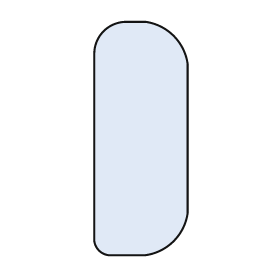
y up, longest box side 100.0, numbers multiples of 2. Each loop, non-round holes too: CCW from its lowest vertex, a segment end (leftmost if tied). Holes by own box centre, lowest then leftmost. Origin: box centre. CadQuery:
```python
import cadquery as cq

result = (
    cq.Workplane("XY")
    .moveTo(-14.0, -50.0)
    .lineTo(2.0, -50.0)
    .threePointArc((14.0, -44.0), (20.0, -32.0))
    .lineTo(20.0, 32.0)
    .threePointArc((14.0, 44.0), (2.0, 50.0))
    .lineTo(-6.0, 50.0)
    .threePointArc((-16.0, 46.0), (-20.0, 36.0))
    .lineTo(-20.0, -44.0)
    .threePointArc((-18.0, -48.0), (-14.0, -50.0))
    .close()
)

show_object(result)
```